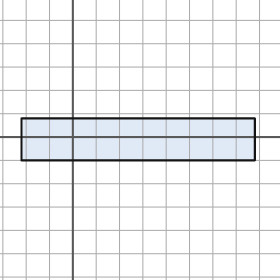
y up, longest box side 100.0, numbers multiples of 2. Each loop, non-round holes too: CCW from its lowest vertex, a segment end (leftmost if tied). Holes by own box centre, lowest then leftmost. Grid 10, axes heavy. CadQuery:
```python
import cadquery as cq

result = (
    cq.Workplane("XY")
    .moveTo(-22.0, -10.0)
    .lineTo(78.0, -10.0)
    .lineTo(78.0, 8.0)
    .lineTo(-22.0, 8.0)
    .close()
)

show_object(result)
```